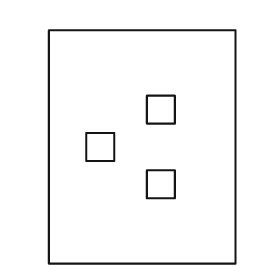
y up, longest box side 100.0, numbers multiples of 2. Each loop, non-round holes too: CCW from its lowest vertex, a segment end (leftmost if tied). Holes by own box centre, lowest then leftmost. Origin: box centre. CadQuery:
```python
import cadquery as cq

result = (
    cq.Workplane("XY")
    .moveTo(-40.0, -50.0)
    .lineTo(40.0, -50.0)
    .lineTo(40.0, 50.0)
    .lineTo(-40.0, 50.0)
    .close()
    .moveTo(2.0, -22.0)
    .lineTo(14.0, -22.0)
    .lineTo(14.0, -10.0)
    .lineTo(2.0, -10.0)
    .close()
    .moveTo(-24.0, -6.0)
    .lineTo(-12.0, -6.0)
    .lineTo(-12.0, 6.0)
    .lineTo(-24.0, 6.0)
    .close()
    .moveTo(2.0, 10.0)
    .lineTo(14.0, 10.0)
    .lineTo(14.0, 22.0)
    .lineTo(2.0, 22.0)
    .close()
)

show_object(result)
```